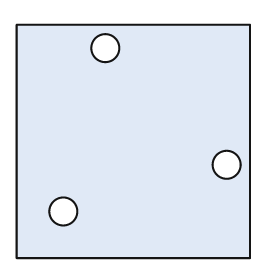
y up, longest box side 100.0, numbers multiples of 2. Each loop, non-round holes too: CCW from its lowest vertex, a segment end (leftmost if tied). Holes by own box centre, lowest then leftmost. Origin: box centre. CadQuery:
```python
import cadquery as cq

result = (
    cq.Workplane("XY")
    .moveTo(-50.0, -50.0)
    .lineTo(50.0, -50.0)
    .lineTo(50.0, 50.0)
    .lineTo(-50.0, 50.0)
    .close()
    .moveTo(-30.0, -30.0)
    .circle(6.0)
    .moveTo(40.0, -10.0)
    .circle(6.0)
    .moveTo(-12.0, 40.0)
    .circle(6.0)
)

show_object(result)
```